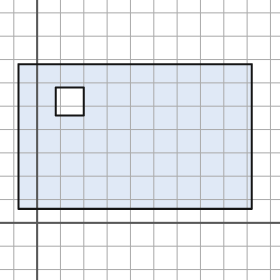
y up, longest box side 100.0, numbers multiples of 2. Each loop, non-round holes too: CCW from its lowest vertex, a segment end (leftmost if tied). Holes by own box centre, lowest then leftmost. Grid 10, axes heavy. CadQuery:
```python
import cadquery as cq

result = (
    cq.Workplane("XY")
    .moveTo(-8.0, 6.0)
    .lineTo(92.0, 6.0)
    .lineTo(92.0, 68.0)
    .lineTo(-8.0, 68.0)
    .close()
    .moveTo(8.0, 46.0)
    .lineTo(20.0, 46.0)
    .lineTo(20.0, 58.0)
    .lineTo(8.0, 58.0)
    .close()
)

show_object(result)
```